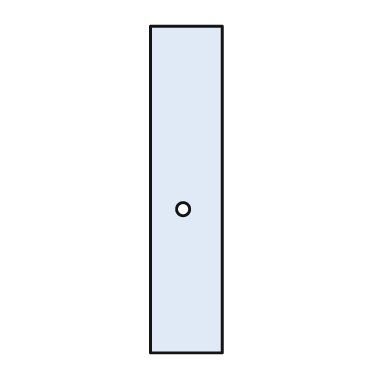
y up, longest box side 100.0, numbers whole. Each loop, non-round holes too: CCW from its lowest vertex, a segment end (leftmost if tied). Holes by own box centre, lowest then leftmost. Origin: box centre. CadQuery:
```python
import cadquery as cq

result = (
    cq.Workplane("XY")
    .moveTo(-11.0, -50.0)
    .lineTo(11.0, -50.0)
    .lineTo(11.0, 50.0)
    .lineTo(-11.0, 50.0)
    .close()
    .moveTo(-1.0, -6.0)
    .circle(2.0)
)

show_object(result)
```